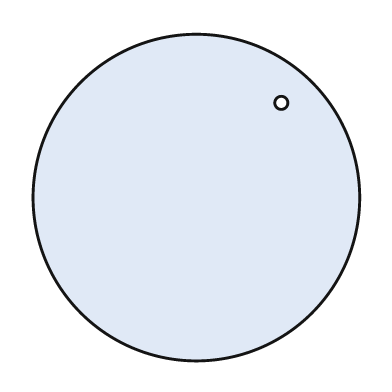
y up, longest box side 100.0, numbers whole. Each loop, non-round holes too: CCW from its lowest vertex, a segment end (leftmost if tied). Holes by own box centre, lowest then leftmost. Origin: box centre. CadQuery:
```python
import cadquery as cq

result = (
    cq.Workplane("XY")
    .moveTo(0.0, 0.0)
    .circle(50.0)
    .moveTo(26.0, 29.0)
    .circle(2.0)
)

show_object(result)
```